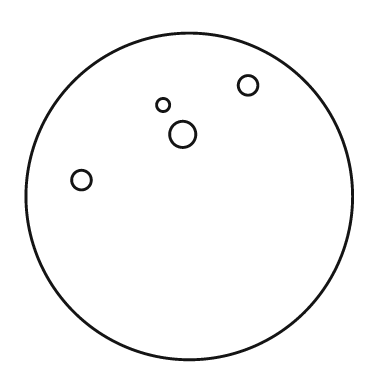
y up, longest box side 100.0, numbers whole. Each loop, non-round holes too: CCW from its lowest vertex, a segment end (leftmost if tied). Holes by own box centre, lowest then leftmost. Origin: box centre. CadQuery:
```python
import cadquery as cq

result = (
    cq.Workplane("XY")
    .moveTo(0.0, 0.0)
    .circle(50.0)
    .moveTo(-33.0, 5.0)
    .circle(3.0)
    .moveTo(-2.0, 19.0)
    .circle(4.0)
    .moveTo(-8.0, 28.0)
    .circle(2.0)
    .moveTo(18.0, 34.0)
    .circle(3.0)
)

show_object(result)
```